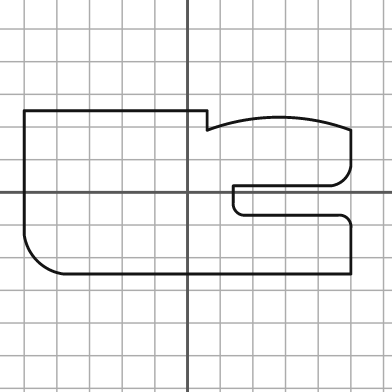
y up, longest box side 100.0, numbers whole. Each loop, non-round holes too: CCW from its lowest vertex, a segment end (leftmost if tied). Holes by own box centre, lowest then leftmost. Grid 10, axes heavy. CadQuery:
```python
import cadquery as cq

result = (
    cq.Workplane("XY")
    .moveTo(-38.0, -25.0)
    .lineTo(50.0, -25.0)
    .lineTo(50.0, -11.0)
    .threePointArc((49.0, -8.0), (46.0, -7.0))
    .lineTo(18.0, -7.0)
    .threePointArc((15.0, -6.0), (14.0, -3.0))
    .lineTo(14.0, 2.0)
    .lineTo(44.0, 2.0)
    .threePointArc((48.0, 4.0), (50.0, 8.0))
    .lineTo(50.0, 19.0)
    .threePointArc((28.0, 23.0), (6.0, 19.0))
    .lineTo(6.0, 25.0)
    .lineTo(-50.0, 25.0)
    .lineTo(-50.0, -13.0)
    .threePointArc((-46.0, -21.0), (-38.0, -25.0))
    .close()
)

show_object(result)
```